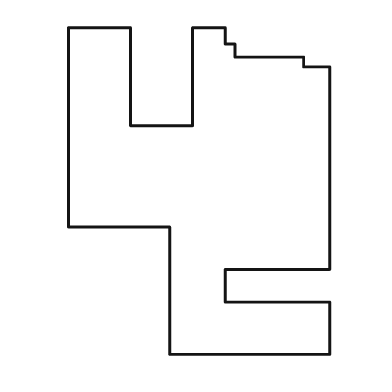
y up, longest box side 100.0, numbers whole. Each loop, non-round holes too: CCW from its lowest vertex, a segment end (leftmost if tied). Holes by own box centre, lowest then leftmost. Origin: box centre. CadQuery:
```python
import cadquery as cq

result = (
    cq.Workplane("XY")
    .moveTo(-9.0, -50.0)
    .lineTo(40.0, -50.0)
    .lineTo(40.0, -34.0)
    .lineTo(8.0, -34.0)
    .lineTo(8.0, -24.0)
    .lineTo(40.0, -24.0)
    .lineTo(40.0, 38.0)
    .lineTo(32.0, 38.0)
    .lineTo(32.0, 41.0)
    .lineTo(11.0, 41.0)
    .lineTo(11.0, 45.0)
    .lineTo(8.0, 45.0)
    .lineTo(8.0, 50.0)
    .lineTo(-2.0, 50.0)
    .lineTo(-2.0, 20.0)
    .lineTo(-21.0, 20.0)
    .lineTo(-21.0, 50.0)
    .lineTo(-40.0, 50.0)
    .lineTo(-40.0, -11.0)
    .lineTo(-9.0, -11.0)
    .close()
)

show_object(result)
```